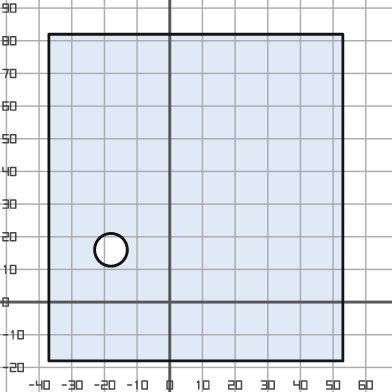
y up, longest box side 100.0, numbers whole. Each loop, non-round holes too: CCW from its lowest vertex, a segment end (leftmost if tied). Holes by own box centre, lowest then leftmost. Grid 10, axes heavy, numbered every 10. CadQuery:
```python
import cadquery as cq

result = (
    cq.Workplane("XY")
    .moveTo(-37.0, -18.0)
    .lineTo(53.0, -18.0)
    .lineTo(53.0, 82.0)
    .lineTo(-37.0, 82.0)
    .close()
    .moveTo(-18.0, 16.0)
    .circle(5.0)
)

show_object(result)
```